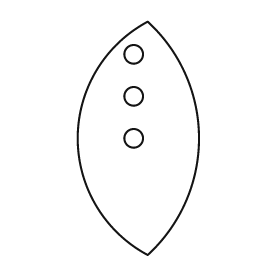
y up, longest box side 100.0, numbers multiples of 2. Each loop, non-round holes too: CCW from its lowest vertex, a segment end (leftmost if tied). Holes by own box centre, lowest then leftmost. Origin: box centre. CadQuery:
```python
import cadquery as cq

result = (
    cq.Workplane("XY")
    .moveTo(4.0, -50.0)
    .threePointArc((26.0, 0.0), (4.0, 50.0))
    .threePointArc((-26.0, 0.0), (4.0, -50.0))
    .close()
    .moveTo(-2.0, 0.0)
    .circle(4.0)
    .moveTo(-2.0, 18.0)
    .circle(4.0)
    .moveTo(-2.0, 36.0)
    .circle(4.0)
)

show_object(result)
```